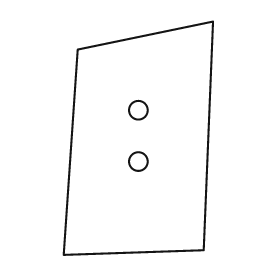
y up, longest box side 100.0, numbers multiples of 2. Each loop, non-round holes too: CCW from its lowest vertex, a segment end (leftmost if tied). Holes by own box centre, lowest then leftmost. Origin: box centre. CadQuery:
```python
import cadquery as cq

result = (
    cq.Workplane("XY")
    .moveTo(-32.0, -50.0)
    .lineTo(28.0, -48.0)
    .lineTo(32.0, 50.0)
    .lineTo(-26.0, 38.0)
    .close()
    .moveTo(0.0, -10.0)
    .circle(4.0)
    .moveTo(0.0, 12.0)
    .circle(4.0)
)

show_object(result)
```